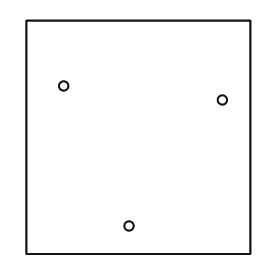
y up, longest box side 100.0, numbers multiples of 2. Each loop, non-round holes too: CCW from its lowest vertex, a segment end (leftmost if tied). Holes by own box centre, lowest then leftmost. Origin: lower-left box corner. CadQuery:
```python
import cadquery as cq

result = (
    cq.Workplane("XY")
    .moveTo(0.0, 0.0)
    .lineTo(96.0, 0.0)
    .lineTo(96.0, 100.0)
    .lineTo(0.0, 100.0)
    .close()
    .moveTo(44.0, 12.0)
    .circle(2.0)
    .moveTo(84.0, 66.0)
    .circle(2.0)
    .moveTo(16.0, 72.0)
    .circle(2.0)
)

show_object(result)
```